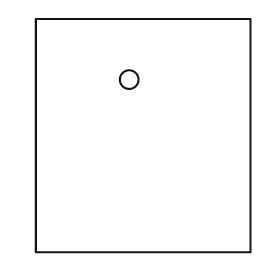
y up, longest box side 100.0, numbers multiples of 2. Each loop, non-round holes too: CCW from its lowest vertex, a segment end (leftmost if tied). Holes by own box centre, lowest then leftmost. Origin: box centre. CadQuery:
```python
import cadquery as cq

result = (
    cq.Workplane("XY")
    .moveTo(-46.0, -50.0)
    .lineTo(46.0, -50.0)
    .lineTo(46.0, 50.0)
    .lineTo(-46.0, 50.0)
    .close()
    .moveTo(-6.0, 24.0)
    .circle(4.0)
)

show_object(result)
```